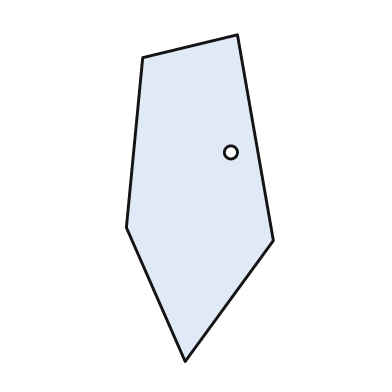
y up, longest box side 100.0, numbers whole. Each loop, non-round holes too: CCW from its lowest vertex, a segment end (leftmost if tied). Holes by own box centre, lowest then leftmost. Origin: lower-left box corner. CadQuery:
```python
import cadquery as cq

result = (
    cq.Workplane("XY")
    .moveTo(18.0, 0.0)
    .lineTo(45.0, 37.0)
    .lineTo(34.0, 100.0)
    .lineTo(5.0, 93.0)
    .lineTo(0.0, 41.0)
    .close()
    .moveTo(32.0, 64.0)
    .circle(2.0)
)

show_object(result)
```